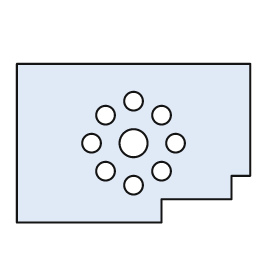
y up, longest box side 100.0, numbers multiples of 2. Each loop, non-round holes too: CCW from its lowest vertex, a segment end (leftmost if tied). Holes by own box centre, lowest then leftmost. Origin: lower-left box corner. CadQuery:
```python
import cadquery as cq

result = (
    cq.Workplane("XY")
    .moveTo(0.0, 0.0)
    .lineTo(62.0, 0.0)
    .lineTo(62.0, 10.0)
    .lineTo(92.0, 10.0)
    .lineTo(92.0, 20.0)
    .lineTo(100.0, 20.0)
    .lineTo(100.0, 68.0)
    .lineTo(0.0, 68.0)
    .close()
    .moveTo(50.0, 16.0)
    .circle(4.0)
    .moveTo(38.0, 22.0)
    .circle(4.0)
    .moveTo(62.0, 22.0)
    .circle(4.0)
    .moveTo(32.0, 34.0)
    .circle(4.0)
    .moveTo(50.0, 34.0)
    .circle(6.0)
    .moveTo(68.0, 34.0)
    .circle(4.0)
    .moveTo(38.0, 46.0)
    .circle(4.0)
    .moveTo(62.0, 46.0)
    .circle(4.0)
    .moveTo(50.0, 52.0)
    .circle(4.0)
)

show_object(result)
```